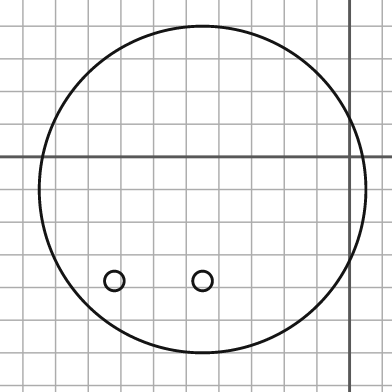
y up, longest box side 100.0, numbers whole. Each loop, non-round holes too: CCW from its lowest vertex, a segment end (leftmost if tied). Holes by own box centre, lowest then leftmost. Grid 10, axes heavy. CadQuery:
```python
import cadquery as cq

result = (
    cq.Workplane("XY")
    .moveTo(-45.0, -10.0)
    .circle(50.0)
    .moveTo(-72.0, -38.0)
    .circle(3.0)
    .moveTo(-45.0, -38.0)
    .circle(3.0)
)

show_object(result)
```